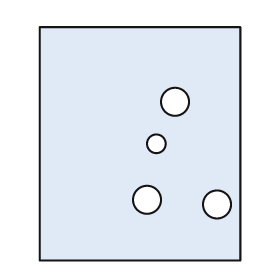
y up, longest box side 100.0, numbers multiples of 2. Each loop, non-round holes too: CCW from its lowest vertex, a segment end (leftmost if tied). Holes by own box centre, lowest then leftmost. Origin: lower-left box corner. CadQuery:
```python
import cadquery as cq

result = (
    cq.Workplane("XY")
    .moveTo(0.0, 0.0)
    .lineTo(86.0, 0.0)
    .lineTo(86.0, 100.0)
    .lineTo(0.0, 100.0)
    .close()
    .moveTo(76.0, 24.0)
    .circle(6.0)
    .moveTo(46.0, 26.0)
    .circle(6.0)
    .moveTo(50.0, 50.0)
    .circle(4.0)
    .moveTo(58.0, 68.0)
    .circle(6.0)
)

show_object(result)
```